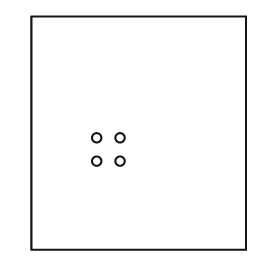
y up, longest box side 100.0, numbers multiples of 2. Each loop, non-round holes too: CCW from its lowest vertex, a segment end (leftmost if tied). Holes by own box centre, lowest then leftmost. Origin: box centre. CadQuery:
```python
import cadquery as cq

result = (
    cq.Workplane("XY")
    .moveTo(-46.0, -50.0)
    .lineTo(46.0, -50.0)
    .lineTo(46.0, 50.0)
    .lineTo(-46.0, 50.0)
    .close()
    .moveTo(-18.0, -12.0)
    .circle(2.0)
    .moveTo(-8.0, -12.0)
    .circle(2.0)
    .moveTo(-18.0, -2.0)
    .circle(2.0)
    .moveTo(-8.0, -2.0)
    .circle(2.0)
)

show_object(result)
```